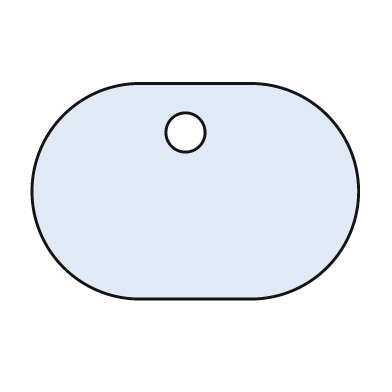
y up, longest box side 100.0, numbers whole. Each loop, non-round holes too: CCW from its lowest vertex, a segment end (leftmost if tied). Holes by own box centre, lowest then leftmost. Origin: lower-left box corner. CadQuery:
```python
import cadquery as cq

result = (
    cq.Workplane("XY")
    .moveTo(33.0, 0.0)
    .lineTo(67.0, 0.0)
    .threePointArc((100.0, 33.0), (67.0, 66.0))
    .lineTo(33.0, 66.0)
    .threePointArc((0.0, 33.0), (33.0, 0.0))
    .close()
    .moveTo(47.0, 51.0)
    .circle(6.0)
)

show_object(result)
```